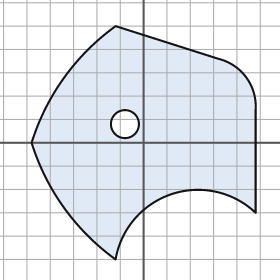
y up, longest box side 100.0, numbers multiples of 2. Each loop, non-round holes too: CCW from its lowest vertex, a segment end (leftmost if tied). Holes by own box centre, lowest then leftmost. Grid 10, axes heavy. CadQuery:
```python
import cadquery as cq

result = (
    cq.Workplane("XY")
    .moveTo(-12.0, -50.0)
    .threePointArc((12.0, -22.0), (48.0, -30.0))
    .lineTo(48.0, 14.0)
    .threePointArc((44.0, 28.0), (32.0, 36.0))
    .lineTo(-12.0, 50.0)
    .threePointArc((-34.0, 28.0), (-48.0, 0.0))
    .threePointArc((-34.0, -28.0), (-12.0, -50.0))
    .close()
    .moveTo(-8.0, 8.0)
    .circle(6.0)
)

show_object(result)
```